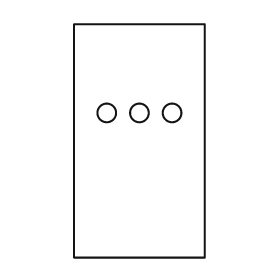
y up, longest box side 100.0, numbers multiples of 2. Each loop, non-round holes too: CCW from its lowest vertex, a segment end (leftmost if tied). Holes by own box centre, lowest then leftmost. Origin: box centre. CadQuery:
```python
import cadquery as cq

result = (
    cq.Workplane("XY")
    .moveTo(-28.0, -50.0)
    .lineTo(28.0, -50.0)
    .lineTo(28.0, 50.0)
    .lineTo(-28.0, 50.0)
    .close()
    .moveTo(-14.0, 12.0)
    .circle(4.0)
    .moveTo(0.0, 12.0)
    .circle(4.0)
    .moveTo(14.0, 12.0)
    .circle(4.0)
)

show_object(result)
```